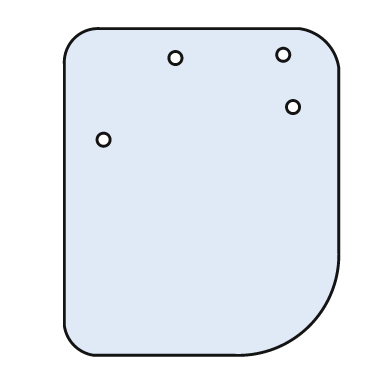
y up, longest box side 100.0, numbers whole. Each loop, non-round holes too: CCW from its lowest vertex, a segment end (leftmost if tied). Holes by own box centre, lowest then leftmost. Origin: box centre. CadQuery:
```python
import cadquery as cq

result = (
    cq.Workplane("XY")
    .moveTo(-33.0, -50.0)
    .lineTo(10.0, -50.0)
    .threePointArc((33.0, -41.0), (42.0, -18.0))
    .lineTo(42.0, 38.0)
    .threePointArc((38.0, 46.0), (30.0, 50.0))
    .lineTo(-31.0, 50.0)
    .threePointArc((-39.0, 47.0), (-42.0, 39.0))
    .lineTo(-42.0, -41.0)
    .threePointArc((-39.0, -47.0), (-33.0, -50.0))
    .close()
    .moveTo(-30.0, 16.0)
    .circle(2.0)
    .moveTo(28.0, 26.0)
    .circle(2.0)
    .moveTo(-8.0, 41.0)
    .circle(2.0)
    .moveTo(25.0, 42.0)
    .circle(2.0)
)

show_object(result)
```